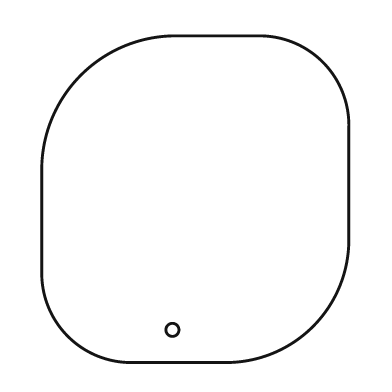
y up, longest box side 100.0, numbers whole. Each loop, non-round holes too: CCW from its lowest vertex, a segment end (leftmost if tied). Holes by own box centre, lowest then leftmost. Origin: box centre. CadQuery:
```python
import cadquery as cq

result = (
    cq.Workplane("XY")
    .moveTo(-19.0, -50.0)
    .lineTo(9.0, -50.0)
    .threePointArc((36.0, -39.0), (47.0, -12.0))
    .lineTo(47.0, 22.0)
    .threePointArc((39.0, 42.0), (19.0, 50.0))
    .lineTo(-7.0, 50.0)
    .threePointArc((-35.0, 38.0), (-47.0, 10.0))
    .lineTo(-47.0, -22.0)
    .threePointArc((-39.0, -42.0), (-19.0, -50.0))
    .close()
    .moveTo(-7.0, -40.0)
    .circle(2.0)
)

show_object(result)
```